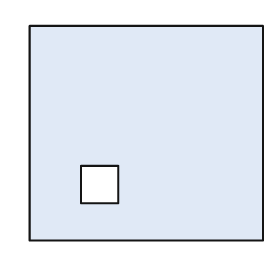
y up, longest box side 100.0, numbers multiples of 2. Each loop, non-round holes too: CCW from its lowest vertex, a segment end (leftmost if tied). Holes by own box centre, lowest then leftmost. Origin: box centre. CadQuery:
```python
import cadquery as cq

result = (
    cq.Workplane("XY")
    .moveTo(-50.0, -46.0)
    .lineTo(50.0, -46.0)
    .lineTo(50.0, 46.0)
    .lineTo(-50.0, 46.0)
    .close()
    .moveTo(-28.0, -30.0)
    .lineTo(-12.0, -30.0)
    .lineTo(-12.0, -14.0)
    .lineTo(-28.0, -14.0)
    .close()
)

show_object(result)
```